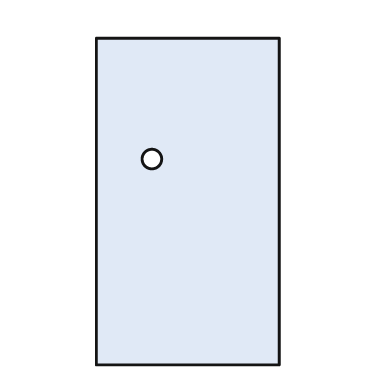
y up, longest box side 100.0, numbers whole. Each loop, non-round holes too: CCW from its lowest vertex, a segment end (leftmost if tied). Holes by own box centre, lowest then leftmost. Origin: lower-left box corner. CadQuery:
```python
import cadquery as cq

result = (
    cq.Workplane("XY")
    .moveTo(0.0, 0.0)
    .lineTo(56.0, 0.0)
    .lineTo(56.0, 100.0)
    .lineTo(0.0, 100.0)
    .close()
    .moveTo(17.0, 63.0)
    .circle(3.0)
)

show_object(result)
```